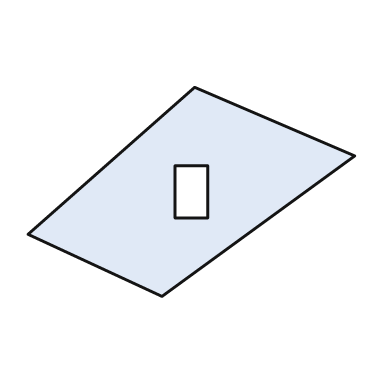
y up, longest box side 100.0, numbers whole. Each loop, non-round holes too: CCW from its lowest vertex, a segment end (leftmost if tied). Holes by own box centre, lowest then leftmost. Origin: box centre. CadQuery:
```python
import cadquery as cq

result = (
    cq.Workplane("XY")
    .moveTo(-9.0, -32.0)
    .lineTo(50.0, 11.0)
    .lineTo(1.0, 32.0)
    .lineTo(-50.0, -13.0)
    .close()
    .moveTo(-5.0, -8.0)
    .lineTo(5.0, -8.0)
    .lineTo(5.0, 8.0)
    .lineTo(-5.0, 8.0)
    .close()
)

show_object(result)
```